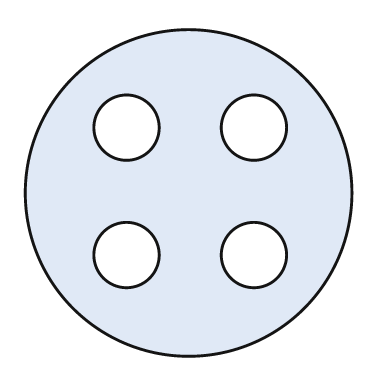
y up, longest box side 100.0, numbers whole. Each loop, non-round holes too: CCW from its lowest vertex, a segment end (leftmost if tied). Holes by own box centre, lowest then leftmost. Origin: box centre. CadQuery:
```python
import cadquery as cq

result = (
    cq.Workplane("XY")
    .moveTo(0.0, 0.0)
    .circle(50.0)
    .moveTo(-19.0, -19.0)
    .circle(10.0)
    .moveTo(20.0, -19.0)
    .circle(10.0)
    .moveTo(-19.0, 20.0)
    .circle(10.0)
    .moveTo(20.0, 20.0)
    .circle(10.0)
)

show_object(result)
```